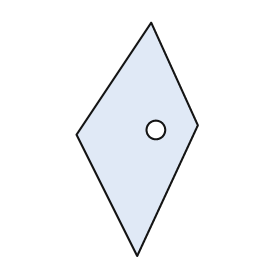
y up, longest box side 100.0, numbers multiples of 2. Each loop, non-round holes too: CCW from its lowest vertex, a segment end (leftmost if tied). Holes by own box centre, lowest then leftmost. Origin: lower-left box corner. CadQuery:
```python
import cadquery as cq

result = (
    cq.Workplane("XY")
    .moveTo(26.0, 0.0)
    .lineTo(52.0, 56.0)
    .lineTo(32.0, 100.0)
    .lineTo(0.0, 52.0)
    .close()
    .moveTo(34.0, 54.0)
    .circle(4.0)
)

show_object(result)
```